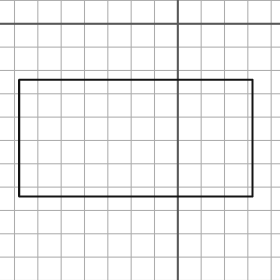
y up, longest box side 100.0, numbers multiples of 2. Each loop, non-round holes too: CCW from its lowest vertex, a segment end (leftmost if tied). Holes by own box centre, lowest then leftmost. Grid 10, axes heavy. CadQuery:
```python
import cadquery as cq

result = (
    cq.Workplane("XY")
    .moveTo(-68.0, -74.0)
    .lineTo(32.0, -74.0)
    .lineTo(32.0, -24.0)
    .lineTo(-68.0, -24.0)
    .close()
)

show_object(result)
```